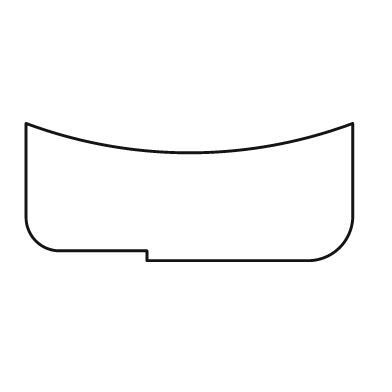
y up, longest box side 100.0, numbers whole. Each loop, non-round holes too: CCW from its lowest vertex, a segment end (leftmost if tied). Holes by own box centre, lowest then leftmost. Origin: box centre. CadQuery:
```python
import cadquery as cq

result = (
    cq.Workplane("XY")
    .moveTo(-13.0, -21.0)
    .lineTo(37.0, -21.0)
    .threePointArc((46.0, -17.0), (50.0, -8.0))
    .lineTo(50.0, 21.0)
    .threePointArc((0.0, 12.0), (-50.0, 21.0))
    .lineTo(-50.0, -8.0)
    .threePointArc((-47.0, -15.0), (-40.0, -18.0))
    .lineTo(-13.0, -18.0)
    .close()
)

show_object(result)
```